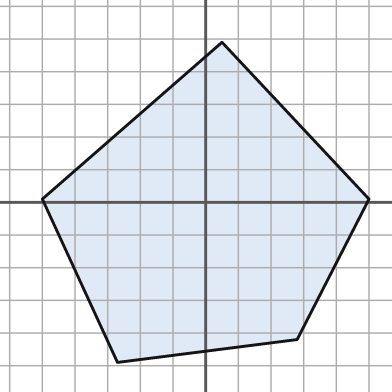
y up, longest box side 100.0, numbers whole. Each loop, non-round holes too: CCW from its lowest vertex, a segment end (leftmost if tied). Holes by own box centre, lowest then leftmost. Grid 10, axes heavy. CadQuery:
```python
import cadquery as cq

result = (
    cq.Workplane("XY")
    .moveTo(-27.0, -49.0)
    .lineTo(28.0, -42.0)
    .lineTo(50.0, 1.0)
    .lineTo(5.0, 49.0)
    .lineTo(-50.0, 1.0)
    .close()
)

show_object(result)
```